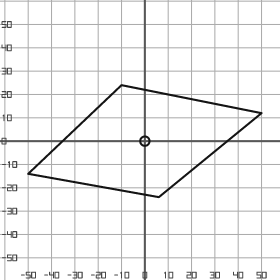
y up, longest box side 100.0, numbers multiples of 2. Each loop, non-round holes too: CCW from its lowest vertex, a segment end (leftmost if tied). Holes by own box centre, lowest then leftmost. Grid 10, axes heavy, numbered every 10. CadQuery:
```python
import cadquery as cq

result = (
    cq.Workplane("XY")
    .moveTo(6.0, -24.0)
    .lineTo(50.0, 12.0)
    .lineTo(-10.0, 24.0)
    .lineTo(-50.0, -14.0)
    .close()
    .moveTo(0.0, 0.0)
    .circle(2.0)
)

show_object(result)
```